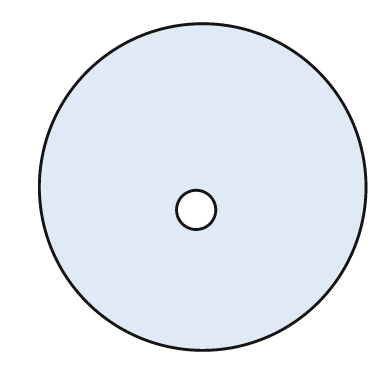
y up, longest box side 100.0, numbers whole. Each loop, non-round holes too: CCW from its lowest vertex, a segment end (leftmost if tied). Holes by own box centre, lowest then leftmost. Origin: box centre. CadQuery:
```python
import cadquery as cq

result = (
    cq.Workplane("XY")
    .moveTo(0.0, 0.0)
    .circle(50.0)
    .moveTo(-2.0, -7.0)
    .circle(6.0)
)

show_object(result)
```